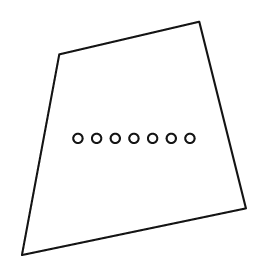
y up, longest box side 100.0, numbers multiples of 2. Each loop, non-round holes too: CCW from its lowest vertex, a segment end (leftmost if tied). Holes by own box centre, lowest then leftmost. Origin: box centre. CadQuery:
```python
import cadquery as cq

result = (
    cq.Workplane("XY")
    .moveTo(-48.0, -50.0)
    .lineTo(48.0, -30.0)
    .lineTo(28.0, 50.0)
    .lineTo(-32.0, 36.0)
    .close()
    .moveTo(-24.0, 0.0)
    .circle(2.0)
    .moveTo(-16.0, 0.0)
    .circle(2.0)
    .moveTo(-8.0, 0.0)
    .circle(2.0)
    .moveTo(0.0, 0.0)
    .circle(2.0)
    .moveTo(8.0, 0.0)
    .circle(2.0)
    .moveTo(16.0, 0.0)
    .circle(2.0)
    .moveTo(24.0, 0.0)
    .circle(2.0)
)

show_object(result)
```